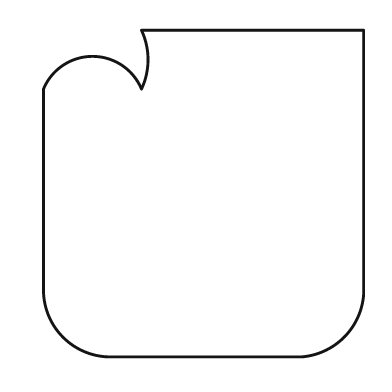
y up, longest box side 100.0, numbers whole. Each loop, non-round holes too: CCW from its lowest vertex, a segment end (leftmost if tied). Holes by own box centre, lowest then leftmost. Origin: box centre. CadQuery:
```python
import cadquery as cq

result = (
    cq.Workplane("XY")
    .moveTo(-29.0, -50.0)
    .lineTo(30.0, -50.0)
    .threePointArc((43.0, -44.0), (49.0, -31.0))
    .lineTo(49.0, 50.0)
    .lineTo(-19.0, 50.0)
    .threePointArc((-17.0, 41.0), (-19.0, 32.0))
    .threePointArc((-34.0, 42.0), (-49.0, 32.0))
    .lineTo(-49.0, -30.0)
    .threePointArc((-43.0, -44.0), (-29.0, -50.0))
    .close()
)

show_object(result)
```